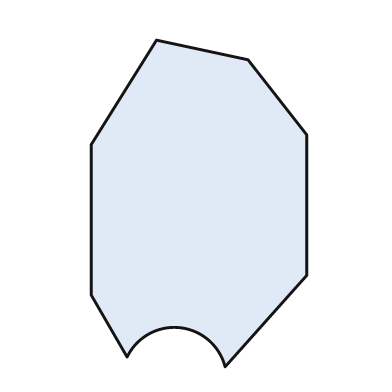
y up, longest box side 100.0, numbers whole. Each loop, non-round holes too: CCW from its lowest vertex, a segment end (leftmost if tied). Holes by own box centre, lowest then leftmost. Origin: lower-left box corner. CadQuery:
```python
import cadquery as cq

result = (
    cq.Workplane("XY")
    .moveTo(41.0, 0.0)
    .lineTo(66.0, 28.0)
    .lineTo(66.0, 71.0)
    .lineTo(48.0, 94.0)
    .lineTo(20.0, 100.0)
    .lineTo(0.0, 68.0)
    .lineTo(0.0, 22.0)
    .lineTo(11.0, 3.0)
    .threePointArc((27.0, 12.0), (41.0, 0.0))
    .close()
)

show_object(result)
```